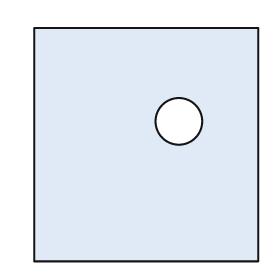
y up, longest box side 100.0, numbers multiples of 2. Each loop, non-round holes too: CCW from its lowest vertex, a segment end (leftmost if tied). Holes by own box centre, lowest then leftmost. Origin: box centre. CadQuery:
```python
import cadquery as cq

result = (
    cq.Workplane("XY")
    .moveTo(-48.0, -50.0)
    .lineTo(48.0, -50.0)
    .lineTo(48.0, 50.0)
    .lineTo(-48.0, 50.0)
    .close()
    .moveTo(14.0, 10.0)
    .circle(10.0)
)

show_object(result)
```